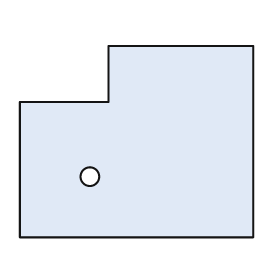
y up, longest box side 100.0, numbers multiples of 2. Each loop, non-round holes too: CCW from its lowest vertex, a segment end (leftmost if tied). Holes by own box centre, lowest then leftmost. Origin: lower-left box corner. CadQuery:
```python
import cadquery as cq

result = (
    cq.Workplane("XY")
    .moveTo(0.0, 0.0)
    .lineTo(100.0, 0.0)
    .lineTo(100.0, 82.0)
    .lineTo(38.0, 82.0)
    .lineTo(38.0, 58.0)
    .lineTo(0.0, 58.0)
    .close()
    .moveTo(30.0, 26.0)
    .circle(4.0)
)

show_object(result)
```